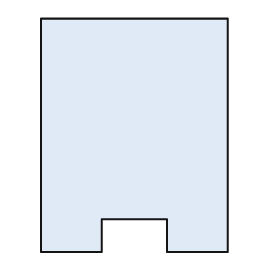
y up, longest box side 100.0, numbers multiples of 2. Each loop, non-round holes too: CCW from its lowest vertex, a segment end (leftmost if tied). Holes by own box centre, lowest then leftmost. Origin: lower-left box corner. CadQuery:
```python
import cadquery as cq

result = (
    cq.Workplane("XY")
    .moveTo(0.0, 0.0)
    .lineTo(26.0, 0.0)
    .lineTo(26.0, 14.0)
    .lineTo(54.0, 14.0)
    .lineTo(54.0, 0.0)
    .lineTo(80.0, 0.0)
    .lineTo(80.0, 100.0)
    .lineTo(0.0, 100.0)
    .close()
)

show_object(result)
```